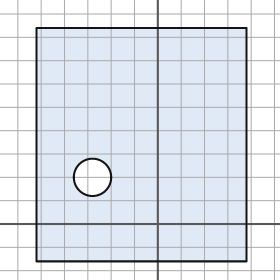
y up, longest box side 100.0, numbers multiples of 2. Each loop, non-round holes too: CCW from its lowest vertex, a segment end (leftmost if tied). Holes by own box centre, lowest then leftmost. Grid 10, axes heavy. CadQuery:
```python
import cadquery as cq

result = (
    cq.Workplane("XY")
    .moveTo(-52.0, -16.0)
    .lineTo(38.0, -16.0)
    .lineTo(38.0, 84.0)
    .lineTo(-52.0, 84.0)
    .close()
    .moveTo(-28.0, 20.0)
    .circle(8.0)
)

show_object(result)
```